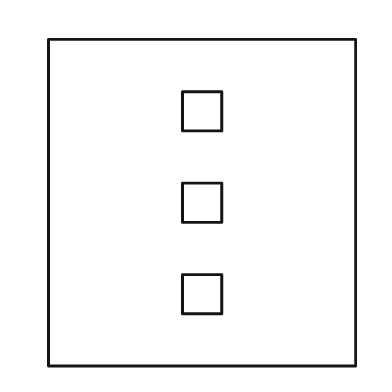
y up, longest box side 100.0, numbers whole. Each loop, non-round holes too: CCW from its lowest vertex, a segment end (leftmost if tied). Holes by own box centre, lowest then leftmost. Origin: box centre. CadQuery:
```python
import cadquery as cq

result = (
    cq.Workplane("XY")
    .moveTo(-47.0, -50.0)
    .lineTo(47.0, -50.0)
    .lineTo(47.0, 50.0)
    .lineTo(-47.0, 50.0)
    .close()
    .moveTo(-6.0, -34.0)
    .lineTo(6.0, -34.0)
    .lineTo(6.0, -22.0)
    .lineTo(-6.0, -22.0)
    .close()
    .moveTo(-6.0, -6.0)
    .lineTo(6.0, -6.0)
    .lineTo(6.0, 6.0)
    .lineTo(-6.0, 6.0)
    .close()
    .moveTo(-6.0, 22.0)
    .lineTo(6.0, 22.0)
    .lineTo(6.0, 34.0)
    .lineTo(-6.0, 34.0)
    .close()
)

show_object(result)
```